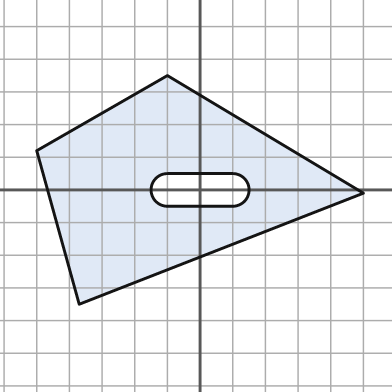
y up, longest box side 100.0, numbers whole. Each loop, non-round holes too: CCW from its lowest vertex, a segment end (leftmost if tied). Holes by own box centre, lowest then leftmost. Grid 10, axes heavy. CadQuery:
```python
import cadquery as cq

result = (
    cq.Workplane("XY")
    .moveTo(-37.0, -35.0)
    .lineTo(50.0, -1.0)
    .lineTo(-10.0, 35.0)
    .lineTo(-50.0, 12.0)
    .close()
    .moveTo(-10.0, -5.0)
    .lineTo(10.0, -5.0)
    .threePointArc((15.0, 0.0), (10.0, 5.0))
    .lineTo(-10.0, 5.0)
    .threePointArc((-15.0, 0.0), (-10.0, -5.0))
    .close()
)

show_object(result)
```